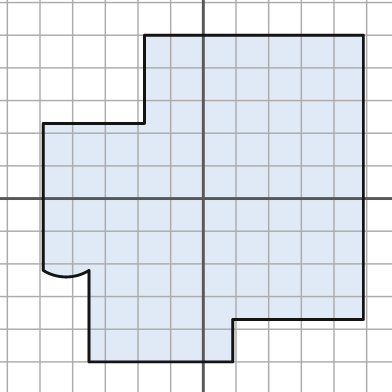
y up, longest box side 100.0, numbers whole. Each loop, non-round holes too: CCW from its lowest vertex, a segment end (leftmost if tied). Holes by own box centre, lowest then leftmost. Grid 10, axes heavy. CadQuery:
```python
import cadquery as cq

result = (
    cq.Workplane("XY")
    .moveTo(-35.0, -50.0)
    .lineTo(9.0, -50.0)
    .lineTo(9.0, -37.0)
    .lineTo(49.0, -37.0)
    .lineTo(49.0, 50.0)
    .lineTo(-18.0, 50.0)
    .lineTo(-18.0, 23.0)
    .lineTo(-49.0, 23.0)
    .lineTo(-49.0, -22.0)
    .threePointArc((-42.0, -24.0), (-35.0, -22.0))
    .close()
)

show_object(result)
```